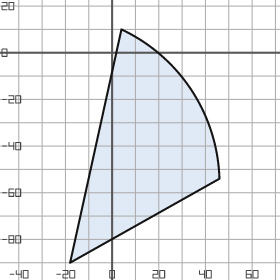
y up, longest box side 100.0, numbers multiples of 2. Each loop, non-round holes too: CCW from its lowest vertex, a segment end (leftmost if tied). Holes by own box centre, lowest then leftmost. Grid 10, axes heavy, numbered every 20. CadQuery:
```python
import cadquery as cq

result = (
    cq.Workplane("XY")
    .moveTo(-18.0, -90.0)
    .lineTo(46.0, -54.0)
    .threePointArc((34.0, -16.0), (4.0, 10.0))
    .close()
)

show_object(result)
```